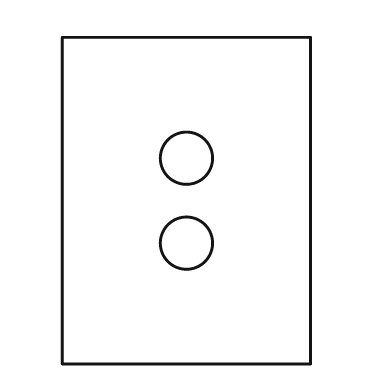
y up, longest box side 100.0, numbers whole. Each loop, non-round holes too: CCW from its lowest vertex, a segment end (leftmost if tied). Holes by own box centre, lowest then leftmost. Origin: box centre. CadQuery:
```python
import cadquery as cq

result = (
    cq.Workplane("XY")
    .moveTo(-38.0, -50.0)
    .lineTo(38.0, -50.0)
    .lineTo(38.0, 50.0)
    .lineTo(-38.0, 50.0)
    .close()
    .moveTo(0.0, -13.0)
    .circle(8.0)
    .moveTo(0.0, 13.0)
    .circle(8.0)
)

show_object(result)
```